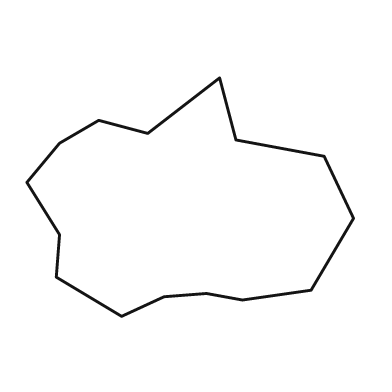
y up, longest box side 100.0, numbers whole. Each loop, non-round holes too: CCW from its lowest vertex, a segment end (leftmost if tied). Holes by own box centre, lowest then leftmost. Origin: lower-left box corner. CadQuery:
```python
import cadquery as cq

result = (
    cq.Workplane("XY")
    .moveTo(29.0, 0.0)
    .lineTo(42.0, 6.0)
    .lineTo(55.0, 7.0)
    .lineTo(66.0, 5.0)
    .lineTo(87.0, 8.0)
    .lineTo(100.0, 30.0)
    .lineTo(91.0, 49.0)
    .lineTo(64.0, 54.0)
    .lineTo(59.0, 73.0)
    .lineTo(37.0, 56.0)
    .lineTo(22.0, 60.0)
    .lineTo(10.0, 53.0)
    .lineTo(0.0, 41.0)
    .lineTo(10.0, 25.0)
    .lineTo(9.0, 12.0)
    .close()
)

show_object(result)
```